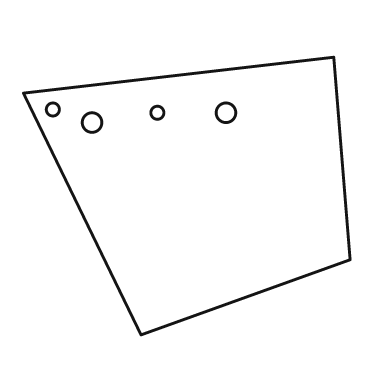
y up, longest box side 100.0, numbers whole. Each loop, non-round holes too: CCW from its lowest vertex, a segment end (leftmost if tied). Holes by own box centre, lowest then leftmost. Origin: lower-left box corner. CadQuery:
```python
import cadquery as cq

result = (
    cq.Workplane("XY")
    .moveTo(36.0, 0.0)
    .lineTo(100.0, 23.0)
    .lineTo(95.0, 85.0)
    .lineTo(0.0, 74.0)
    .close()
    .moveTo(21.0, 65.0)
    .circle(3.0)
    .moveTo(41.0, 68.0)
    .circle(2.0)
    .moveTo(62.0, 68.0)
    .circle(3.0)
    .moveTo(9.0, 69.0)
    .circle(2.0)
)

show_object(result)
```